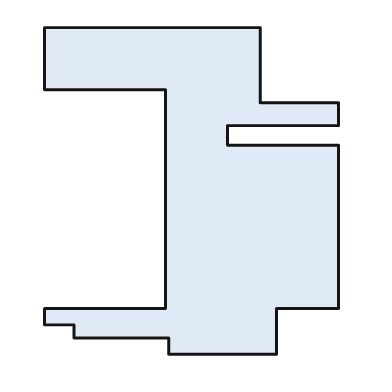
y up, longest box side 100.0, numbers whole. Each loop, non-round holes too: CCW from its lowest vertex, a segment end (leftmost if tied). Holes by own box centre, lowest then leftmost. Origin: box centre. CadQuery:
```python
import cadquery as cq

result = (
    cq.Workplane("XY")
    .moveTo(-7.0, -50.0)
    .lineTo(26.0, -50.0)
    .lineTo(26.0, -36.0)
    .lineTo(45.0, -36.0)
    .lineTo(45.0, 14.0)
    .lineTo(11.0, 14.0)
    .lineTo(11.0, 20.0)
    .lineTo(45.0, 20.0)
    .lineTo(45.0, 27.0)
    .lineTo(21.0, 27.0)
    .lineTo(21.0, 50.0)
    .lineTo(-45.0, 50.0)
    .lineTo(-45.0, 31.0)
    .lineTo(-8.0, 31.0)
    .lineTo(-8.0, -36.0)
    .lineTo(-45.0, -36.0)
    .lineTo(-45.0, -41.0)
    .lineTo(-36.0, -41.0)
    .lineTo(-36.0, -45.0)
    .lineTo(-7.0, -45.0)
    .close()
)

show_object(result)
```